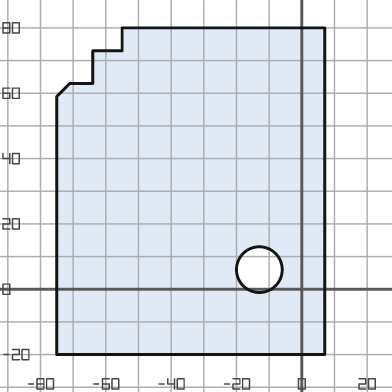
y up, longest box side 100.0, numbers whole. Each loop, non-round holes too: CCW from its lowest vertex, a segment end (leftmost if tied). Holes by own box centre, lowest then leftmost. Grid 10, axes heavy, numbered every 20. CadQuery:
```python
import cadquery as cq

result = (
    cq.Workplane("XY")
    .moveTo(-75.0, -20.0)
    .lineTo(7.0, -20.0)
    .lineTo(7.0, 80.0)
    .lineTo(-55.0, 80.0)
    .lineTo(-55.0, 73.0)
    .lineTo(-64.0, 73.0)
    .lineTo(-64.0, 63.0)
    .lineTo(-71.0, 63.0)
    .lineTo(-75.0, 59.0)
    .close()
    .moveTo(-13.0, 6.0)
    .circle(7.0)
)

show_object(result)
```